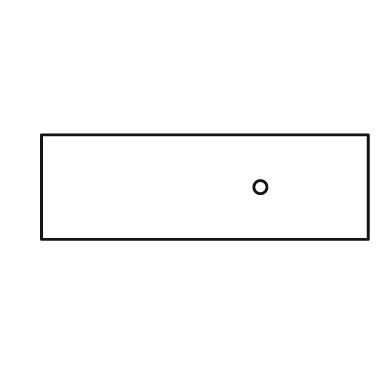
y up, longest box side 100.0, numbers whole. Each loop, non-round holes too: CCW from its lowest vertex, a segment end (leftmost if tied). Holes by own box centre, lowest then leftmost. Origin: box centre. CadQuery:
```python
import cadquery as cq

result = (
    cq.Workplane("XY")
    .moveTo(-50.0, -16.0)
    .lineTo(50.0, -16.0)
    .lineTo(50.0, 16.0)
    .lineTo(-50.0, 16.0)
    .close()
    .moveTo(17.0, 0.0)
    .circle(2.0)
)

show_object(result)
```